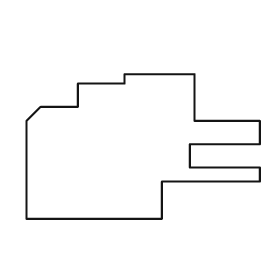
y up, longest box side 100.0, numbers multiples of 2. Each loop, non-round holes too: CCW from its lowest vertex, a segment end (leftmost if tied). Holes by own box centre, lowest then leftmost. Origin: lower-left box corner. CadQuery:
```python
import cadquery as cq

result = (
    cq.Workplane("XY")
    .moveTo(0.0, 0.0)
    .lineTo(58.0, 0.0)
    .lineTo(58.0, 16.0)
    .lineTo(100.0, 16.0)
    .lineTo(100.0, 22.0)
    .lineTo(70.0, 22.0)
    .lineTo(70.0, 32.0)
    .lineTo(100.0, 32.0)
    .lineTo(100.0, 42.0)
    .lineTo(72.0, 42.0)
    .lineTo(72.0, 62.0)
    .lineTo(42.0, 62.0)
    .lineTo(42.0, 58.0)
    .lineTo(22.0, 58.0)
    .lineTo(22.0, 48.0)
    .lineTo(6.0, 48.0)
    .lineTo(0.0, 42.0)
    .close()
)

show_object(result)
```